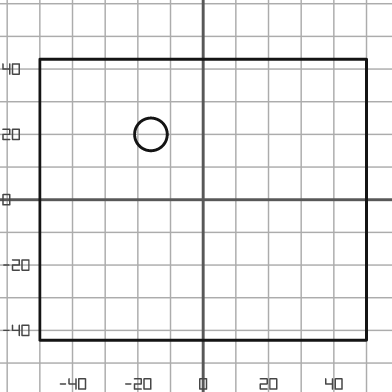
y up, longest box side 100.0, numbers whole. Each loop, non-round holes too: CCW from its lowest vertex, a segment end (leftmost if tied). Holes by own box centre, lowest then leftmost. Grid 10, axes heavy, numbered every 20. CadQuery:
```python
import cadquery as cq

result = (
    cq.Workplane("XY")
    .moveTo(-50.0, -43.0)
    .lineTo(50.0, -43.0)
    .lineTo(50.0, 43.0)
    .lineTo(-50.0, 43.0)
    .close()
    .moveTo(-16.0, 20.0)
    .circle(5.0)
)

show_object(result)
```